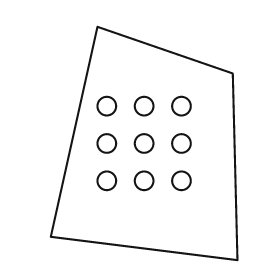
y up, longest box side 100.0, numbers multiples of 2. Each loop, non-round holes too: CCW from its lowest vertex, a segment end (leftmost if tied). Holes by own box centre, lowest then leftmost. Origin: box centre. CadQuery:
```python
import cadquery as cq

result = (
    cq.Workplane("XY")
    .moveTo(40.0, -50.0)
    .lineTo(38.0, 30.0)
    .lineTo(-20.0, 50.0)
    .lineTo(-40.0, -40.0)
    .close()
    .moveTo(-16.0, -16.0)
    .circle(4.0)
    .moveTo(0.0, -16.0)
    .circle(4.0)
    .moveTo(16.0, -16.0)
    .circle(4.0)
    .moveTo(-16.0, 0.0)
    .circle(4.0)
    .moveTo(0.0, 0.0)
    .circle(4.0)
    .moveTo(16.0, 0.0)
    .circle(4.0)
    .moveTo(-16.0, 16.0)
    .circle(4.0)
    .moveTo(0.0, 16.0)
    .circle(4.0)
    .moveTo(16.0, 16.0)
    .circle(4.0)
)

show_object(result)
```